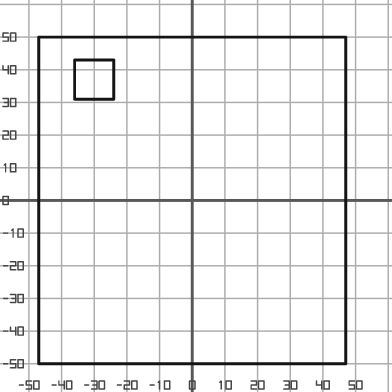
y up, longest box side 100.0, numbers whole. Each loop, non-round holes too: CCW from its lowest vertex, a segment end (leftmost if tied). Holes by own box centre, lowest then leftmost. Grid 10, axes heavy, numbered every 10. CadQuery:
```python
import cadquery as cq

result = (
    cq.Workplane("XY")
    .moveTo(-47.0, -50.0)
    .lineTo(47.0, -50.0)
    .lineTo(47.0, 50.0)
    .lineTo(-47.0, 50.0)
    .close()
    .moveTo(-36.0, 31.0)
    .lineTo(-24.0, 31.0)
    .lineTo(-24.0, 43.0)
    .lineTo(-36.0, 43.0)
    .close()
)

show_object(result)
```